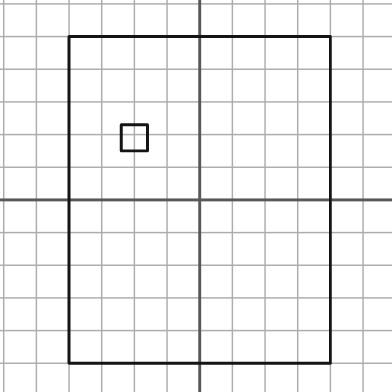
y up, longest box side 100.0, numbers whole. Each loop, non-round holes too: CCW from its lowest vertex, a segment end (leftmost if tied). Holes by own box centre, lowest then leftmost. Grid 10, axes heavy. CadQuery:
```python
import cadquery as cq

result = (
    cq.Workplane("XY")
    .moveTo(-40.0, -50.0)
    .lineTo(40.0, -50.0)
    .lineTo(40.0, 50.0)
    .lineTo(-40.0, 50.0)
    .close()
    .moveTo(-24.0, 15.0)
    .lineTo(-16.0, 15.0)
    .lineTo(-16.0, 23.0)
    .lineTo(-24.0, 23.0)
    .close()
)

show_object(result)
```